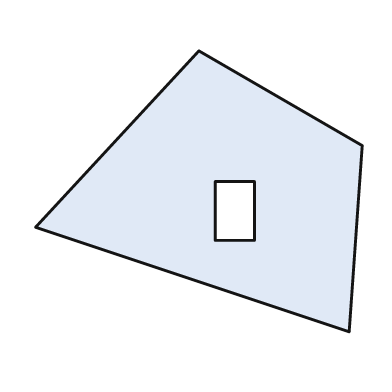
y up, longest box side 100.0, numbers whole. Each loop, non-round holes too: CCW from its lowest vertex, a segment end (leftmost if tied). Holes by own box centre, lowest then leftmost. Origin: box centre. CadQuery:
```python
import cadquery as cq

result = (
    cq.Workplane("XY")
    .moveTo(46.0, -43.0)
    .lineTo(50.0, 14.0)
    .lineTo(0.0, 43.0)
    .lineTo(-50.0, -11.0)
    .close()
    .moveTo(5.0, -15.0)
    .lineTo(17.0, -15.0)
    .lineTo(17.0, 3.0)
    .lineTo(5.0, 3.0)
    .close()
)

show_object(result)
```